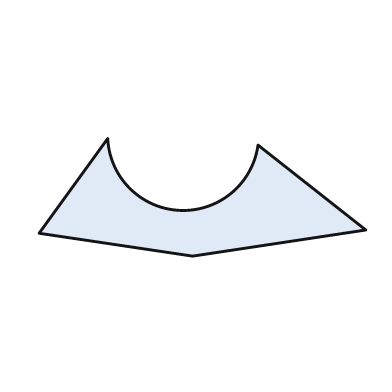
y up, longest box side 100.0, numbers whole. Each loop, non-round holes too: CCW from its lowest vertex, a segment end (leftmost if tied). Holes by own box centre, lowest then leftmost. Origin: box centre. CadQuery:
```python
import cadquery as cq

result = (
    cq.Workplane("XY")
    .moveTo(-3.0, -18.0)
    .lineTo(50.0, -10.0)
    .lineTo(17.0, 16.0)
    .threePointArc((-7.0, -4.0), (-29.0, 18.0))
    .lineTo(-50.0, -11.0)
    .close()
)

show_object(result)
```